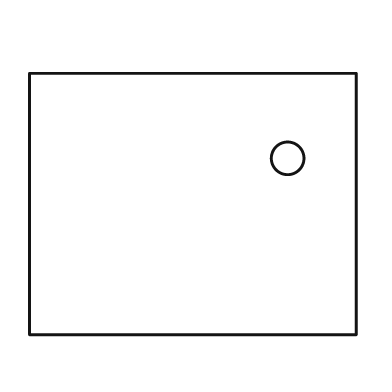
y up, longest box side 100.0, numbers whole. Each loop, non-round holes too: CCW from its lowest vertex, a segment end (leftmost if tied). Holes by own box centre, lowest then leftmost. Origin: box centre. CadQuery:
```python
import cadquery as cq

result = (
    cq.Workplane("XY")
    .moveTo(-50.0, -40.0)
    .lineTo(50.0, -40.0)
    .lineTo(50.0, 40.0)
    .lineTo(-50.0, 40.0)
    .close()
    .moveTo(29.0, 14.0)
    .circle(5.0)
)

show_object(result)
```